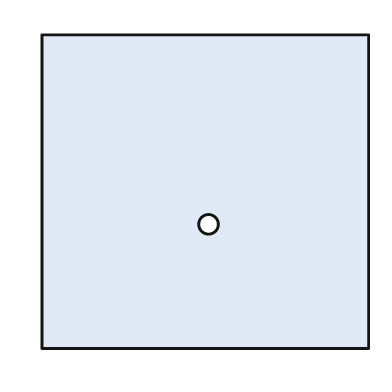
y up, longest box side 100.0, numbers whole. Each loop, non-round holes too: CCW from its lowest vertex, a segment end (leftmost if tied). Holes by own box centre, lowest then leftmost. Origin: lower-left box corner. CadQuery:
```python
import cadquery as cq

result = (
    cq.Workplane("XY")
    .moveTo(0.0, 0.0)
    .lineTo(100.0, 0.0)
    .lineTo(100.0, 96.0)
    .lineTo(0.0, 96.0)
    .close()
    .moveTo(51.0, 38.0)
    .circle(3.0)
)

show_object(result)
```